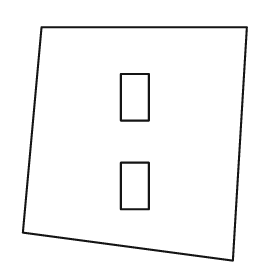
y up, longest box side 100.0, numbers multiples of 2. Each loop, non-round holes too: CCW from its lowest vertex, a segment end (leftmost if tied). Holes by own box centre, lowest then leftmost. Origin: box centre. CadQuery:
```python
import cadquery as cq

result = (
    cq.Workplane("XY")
    .moveTo(42.0, -50.0)
    .lineTo(48.0, 50.0)
    .lineTo(-40.0, 50.0)
    .lineTo(-48.0, -38.0)
    .close()
    .moveTo(-6.0, -28.0)
    .lineTo(6.0, -28.0)
    .lineTo(6.0, -8.0)
    .lineTo(-6.0, -8.0)
    .close()
    .moveTo(-6.0, 10.0)
    .lineTo(6.0, 10.0)
    .lineTo(6.0, 30.0)
    .lineTo(-6.0, 30.0)
    .close()
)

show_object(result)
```